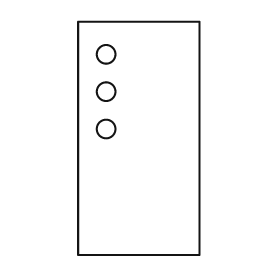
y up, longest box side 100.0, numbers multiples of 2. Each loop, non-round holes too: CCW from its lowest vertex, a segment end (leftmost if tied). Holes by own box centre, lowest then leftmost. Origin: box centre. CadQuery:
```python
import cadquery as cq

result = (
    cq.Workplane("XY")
    .moveTo(-26.0, -50.0)
    .lineTo(26.0, -50.0)
    .lineTo(26.0, 50.0)
    .lineTo(-26.0, 50.0)
    .close()
    .moveTo(-14.0, 4.0)
    .circle(4.0)
    .moveTo(-14.0, 20.0)
    .circle(4.0)
    .moveTo(-14.0, 36.0)
    .circle(4.0)
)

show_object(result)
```